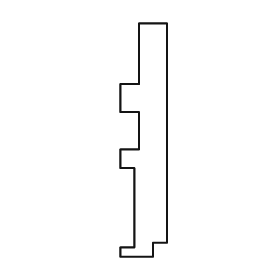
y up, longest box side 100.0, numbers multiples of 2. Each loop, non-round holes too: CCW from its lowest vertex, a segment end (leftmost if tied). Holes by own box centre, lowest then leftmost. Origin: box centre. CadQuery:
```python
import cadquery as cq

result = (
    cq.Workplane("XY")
    .moveTo(-10.0, -50.0)
    .lineTo(4.0, -50.0)
    .lineTo(4.0, -44.0)
    .lineTo(10.0, -44.0)
    .lineTo(10.0, 50.0)
    .lineTo(-2.0, 50.0)
    .lineTo(-2.0, 24.0)
    .lineTo(-10.0, 24.0)
    .lineTo(-10.0, 12.0)
    .lineTo(-2.0, 12.0)
    .lineTo(-2.0, -4.0)
    .lineTo(-10.0, -4.0)
    .lineTo(-10.0, -12.0)
    .lineTo(-4.0, -12.0)
    .lineTo(-4.0, -46.0)
    .lineTo(-10.0, -46.0)
    .close()
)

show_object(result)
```